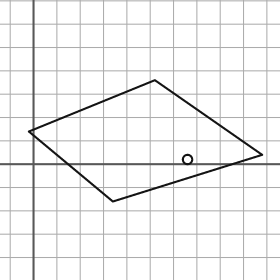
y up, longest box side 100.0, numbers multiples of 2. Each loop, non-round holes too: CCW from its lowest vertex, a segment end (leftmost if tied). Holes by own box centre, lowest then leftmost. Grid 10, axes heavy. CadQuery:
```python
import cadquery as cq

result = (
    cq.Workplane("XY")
    .moveTo(34.0, -16.0)
    .lineTo(98.0, 4.0)
    .lineTo(52.0, 36.0)
    .lineTo(-2.0, 14.0)
    .close()
    .moveTo(66.0, 2.0)
    .circle(2.0)
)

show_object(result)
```